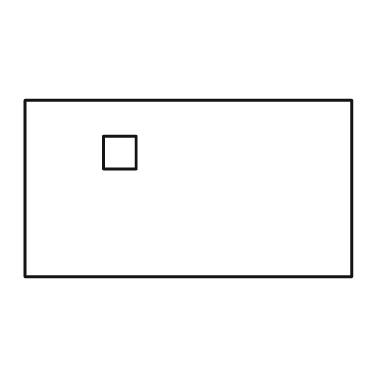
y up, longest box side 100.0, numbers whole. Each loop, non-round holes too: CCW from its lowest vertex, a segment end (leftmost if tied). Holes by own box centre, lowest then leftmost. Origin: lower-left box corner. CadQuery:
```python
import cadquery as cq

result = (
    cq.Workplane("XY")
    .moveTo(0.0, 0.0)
    .lineTo(100.0, 0.0)
    .lineTo(100.0, 54.0)
    .lineTo(0.0, 54.0)
    .close()
    .moveTo(24.0, 33.0)
    .lineTo(34.0, 33.0)
    .lineTo(34.0, 43.0)
    .lineTo(24.0, 43.0)
    .close()
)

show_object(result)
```